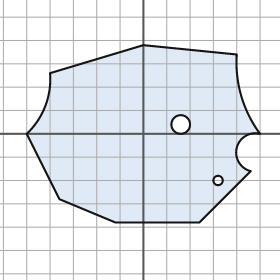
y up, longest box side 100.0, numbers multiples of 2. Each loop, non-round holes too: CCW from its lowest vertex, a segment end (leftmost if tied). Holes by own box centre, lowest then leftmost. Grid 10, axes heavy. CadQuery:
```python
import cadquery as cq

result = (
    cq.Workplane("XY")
    .moveTo(-12.0, -38.0)
    .lineTo(24.0, -38.0)
    .lineTo(46.0, -16.0)
    .threePointArc((40.0, -6.0), (50.0, 0.0))
    .threePointArc((42.0, 16.0), (40.0, 34.0))
    .lineTo(0.0, 38.0)
    .lineTo(-40.0, 26.0)
    .threePointArc((-42.0, 12.0), (-50.0, 0.0))
    .lineTo(-36.0, -28.0)
    .close()
    .moveTo(32.0, -20.0)
    .circle(2.0)
    .moveTo(16.0, 4.0)
    .circle(4.0)
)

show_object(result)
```